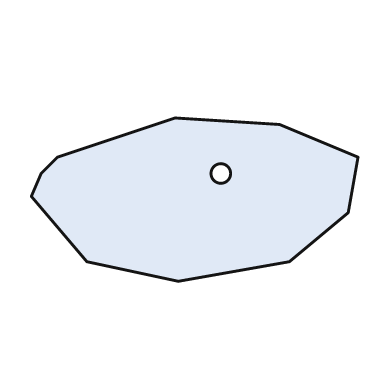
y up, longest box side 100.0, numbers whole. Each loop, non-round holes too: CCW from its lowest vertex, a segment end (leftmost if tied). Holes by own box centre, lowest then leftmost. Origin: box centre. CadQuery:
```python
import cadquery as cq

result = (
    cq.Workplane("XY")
    .moveTo(-5.0, -25.0)
    .lineTo(29.0, -19.0)
    .lineTo(47.0, -4.0)
    .lineTo(50.0, 13.0)
    .lineTo(26.0, 23.0)
    .lineTo(-6.0, 25.0)
    .lineTo(-42.0, 13.0)
    .lineTo(-47.0, 8.0)
    .lineTo(-50.0, 1.0)
    .lineTo(-33.0, -19.0)
    .close()
    .moveTo(8.0, 8.0)
    .circle(3.0)
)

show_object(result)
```